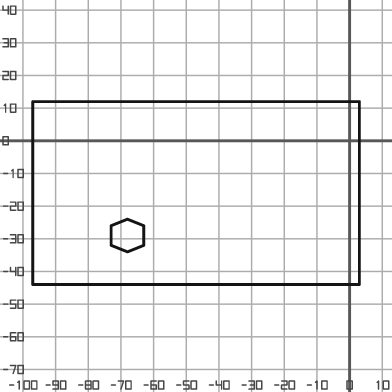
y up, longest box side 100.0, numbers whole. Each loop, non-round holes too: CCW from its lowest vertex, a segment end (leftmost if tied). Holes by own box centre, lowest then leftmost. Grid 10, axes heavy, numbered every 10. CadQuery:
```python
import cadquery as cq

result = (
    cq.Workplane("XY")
    .moveTo(-97.0, -44.0)
    .lineTo(3.0, -44.0)
    .lineTo(3.0, 12.0)
    .lineTo(-97.0, 12.0)
    .close()
    .moveTo(-68.0, -34.0)
    .lineTo(-63.0, -32.0)
    .lineTo(-63.0, -26.0)
    .lineTo(-68.0, -24.0)
    .lineTo(-73.0, -26.0)
    .lineTo(-73.0, -32.0)
    .close()
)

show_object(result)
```